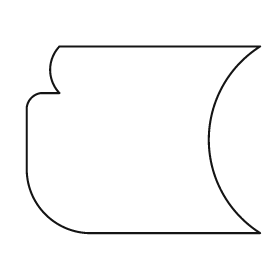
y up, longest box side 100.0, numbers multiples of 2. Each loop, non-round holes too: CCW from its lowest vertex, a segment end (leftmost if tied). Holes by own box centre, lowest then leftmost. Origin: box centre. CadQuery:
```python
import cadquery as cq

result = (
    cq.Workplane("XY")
    .moveTo(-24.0, -40.0)
    .lineTo(50.0, -40.0)
    .threePointArc((28.0, 0.0), (50.0, 40.0))
    .lineTo(-36.0, 40.0)
    .threePointArc((-40.0, 30.0), (-36.0, 20.0))
    .lineTo(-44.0, 20.0)
    .threePointArc((-48.0, 18.0), (-50.0, 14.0))
    .lineTo(-50.0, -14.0)
    .threePointArc((-42.0, -32.0), (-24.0, -40.0))
    .close()
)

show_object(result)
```